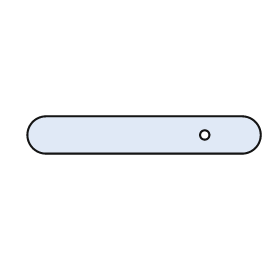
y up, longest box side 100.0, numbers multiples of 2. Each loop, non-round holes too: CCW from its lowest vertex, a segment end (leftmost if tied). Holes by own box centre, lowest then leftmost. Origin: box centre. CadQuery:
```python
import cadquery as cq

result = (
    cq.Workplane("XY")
    .moveTo(-42.0, -8.0)
    .lineTo(42.0, -8.0)
    .threePointArc((50.0, 0.0), (42.0, 8.0))
    .lineTo(-42.0, 8.0)
    .threePointArc((-50.0, 0.0), (-42.0, -8.0))
    .close()
    .moveTo(26.0, 0.0)
    .circle(2.0)
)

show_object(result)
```